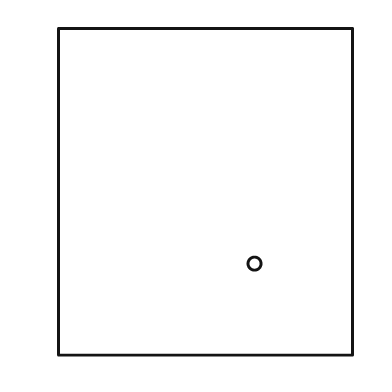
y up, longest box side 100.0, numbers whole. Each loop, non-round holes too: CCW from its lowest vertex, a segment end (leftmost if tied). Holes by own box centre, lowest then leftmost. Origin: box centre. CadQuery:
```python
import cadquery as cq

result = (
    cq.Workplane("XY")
    .moveTo(-45.0, -50.0)
    .lineTo(45.0, -50.0)
    .lineTo(45.0, 50.0)
    .lineTo(-45.0, 50.0)
    .close()
    .moveTo(15.0, -22.0)
    .circle(2.0)
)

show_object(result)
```